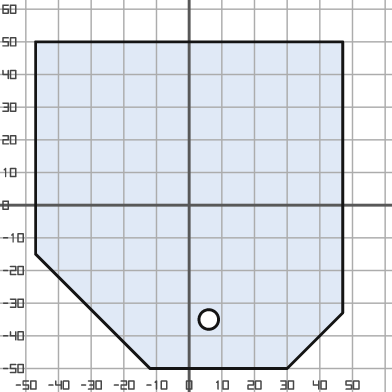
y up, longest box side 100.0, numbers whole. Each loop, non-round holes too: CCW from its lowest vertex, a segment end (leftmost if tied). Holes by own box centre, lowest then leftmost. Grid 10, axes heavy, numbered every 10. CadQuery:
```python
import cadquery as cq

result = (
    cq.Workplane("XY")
    .moveTo(-12.0, -50.0)
    .lineTo(30.0, -50.0)
    .lineTo(47.0, -33.0)
    .lineTo(47.0, 50.0)
    .lineTo(-47.0, 50.0)
    .lineTo(-47.0, -15.0)
    .close()
    .moveTo(6.0, -35.0)
    .circle(3.0)
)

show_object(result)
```